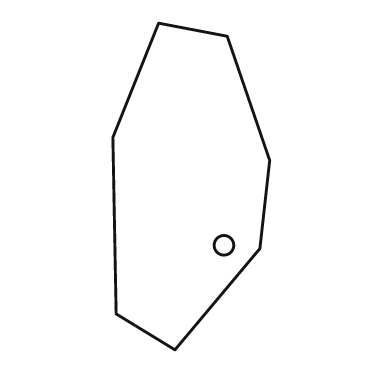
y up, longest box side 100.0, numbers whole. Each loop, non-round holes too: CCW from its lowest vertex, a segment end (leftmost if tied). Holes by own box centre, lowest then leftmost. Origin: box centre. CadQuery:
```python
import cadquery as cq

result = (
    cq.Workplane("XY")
    .moveTo(-5.0, -50.0)
    .lineTo(21.0, -19.0)
    .lineTo(24.0, 8.0)
    .lineTo(11.0, 46.0)
    .lineTo(-10.0, 50.0)
    .lineTo(-24.0, 15.0)
    .lineTo(-23.0, -39.0)
    .close()
    .moveTo(10.0, -18.0)
    .circle(3.0)
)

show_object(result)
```